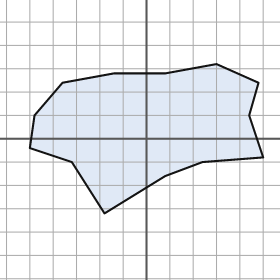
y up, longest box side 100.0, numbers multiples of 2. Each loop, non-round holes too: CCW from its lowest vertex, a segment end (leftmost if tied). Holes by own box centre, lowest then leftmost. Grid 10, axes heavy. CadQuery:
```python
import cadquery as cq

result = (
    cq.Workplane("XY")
    .moveTo(-18.0, -32.0)
    .lineTo(8.0, -16.0)
    .lineTo(24.0, -10.0)
    .lineTo(50.0, -8.0)
    .lineTo(44.0, 10.0)
    .lineTo(48.0, 24.0)
    .lineTo(30.0, 32.0)
    .lineTo(8.0, 28.0)
    .lineTo(-14.0, 28.0)
    .lineTo(-36.0, 24.0)
    .lineTo(-48.0, 10.0)
    .lineTo(-50.0, -4.0)
    .lineTo(-32.0, -10.0)
    .close()
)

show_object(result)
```